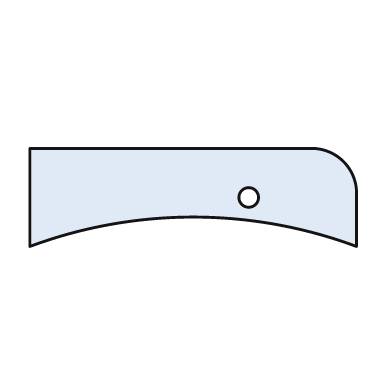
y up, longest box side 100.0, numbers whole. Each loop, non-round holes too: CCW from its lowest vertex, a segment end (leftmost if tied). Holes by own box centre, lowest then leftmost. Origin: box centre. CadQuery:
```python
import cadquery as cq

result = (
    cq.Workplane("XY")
    .moveTo(-50.0, -15.0)
    .threePointArc((0.0, -6.0), (50.0, -15.0))
    .lineTo(50.0, 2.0)
    .threePointArc((46.0, 11.0), (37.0, 15.0))
    .lineTo(-50.0, 15.0)
    .close()
    .moveTo(17.0, 0.0)
    .circle(3.0)
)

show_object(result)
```